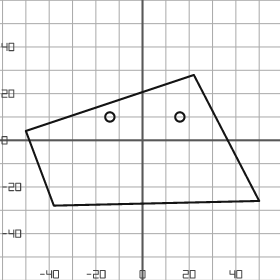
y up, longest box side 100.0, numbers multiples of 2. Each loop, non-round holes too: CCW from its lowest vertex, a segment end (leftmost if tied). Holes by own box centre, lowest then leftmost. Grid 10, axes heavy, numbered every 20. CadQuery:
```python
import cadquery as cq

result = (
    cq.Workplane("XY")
    .moveTo(-38.0, -28.0)
    .lineTo(50.0, -26.0)
    .lineTo(22.0, 28.0)
    .lineTo(-50.0, 4.0)
    .close()
    .moveTo(-14.0, 10.0)
    .circle(2.0)
    .moveTo(16.0, 10.0)
    .circle(2.0)
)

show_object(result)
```